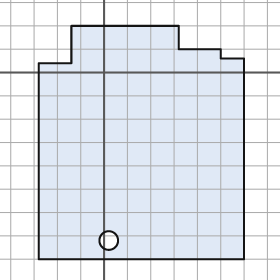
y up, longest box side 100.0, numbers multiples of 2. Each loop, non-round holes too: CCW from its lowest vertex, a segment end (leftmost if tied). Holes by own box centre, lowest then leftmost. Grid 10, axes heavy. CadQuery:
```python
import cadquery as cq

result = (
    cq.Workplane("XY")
    .moveTo(-28.0, -80.0)
    .lineTo(60.0, -80.0)
    .lineTo(60.0, 6.0)
    .lineTo(50.0, 6.0)
    .lineTo(50.0, 10.0)
    .lineTo(32.0, 10.0)
    .lineTo(32.0, 20.0)
    .lineTo(-14.0, 20.0)
    .lineTo(-14.0, 4.0)
    .lineTo(-28.0, 4.0)
    .close()
    .moveTo(2.0, -72.0)
    .circle(4.0)
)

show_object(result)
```